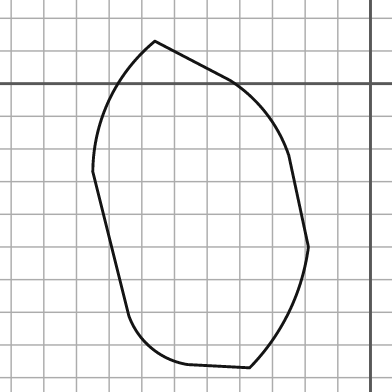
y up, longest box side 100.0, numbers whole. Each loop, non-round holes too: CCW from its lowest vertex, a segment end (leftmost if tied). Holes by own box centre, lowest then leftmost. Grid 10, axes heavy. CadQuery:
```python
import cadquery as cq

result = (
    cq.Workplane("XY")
    .moveTo(-37.0, -87.0)
    .threePointArc((-25.0, -70.0), (-19.0, -50.0))
    .lineTo(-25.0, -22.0)
    .threePointArc((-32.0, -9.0), (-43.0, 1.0))
    .lineTo(-66.0, 13.0)
    .threePointArc((-80.0, -5.0), (-85.0, -27.0))
    .lineTo(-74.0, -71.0)
    .threePointArc((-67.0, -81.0), (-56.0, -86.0))
    .close()
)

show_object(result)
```